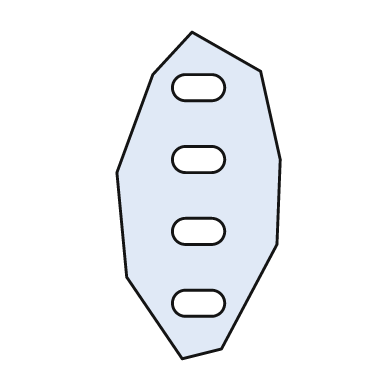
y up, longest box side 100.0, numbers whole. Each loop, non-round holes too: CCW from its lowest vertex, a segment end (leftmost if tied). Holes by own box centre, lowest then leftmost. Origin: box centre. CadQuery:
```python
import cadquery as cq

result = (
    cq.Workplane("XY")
    .moveTo(-5.0, -50.0)
    .lineTo(7.0, -47.0)
    .lineTo(24.0, -15.0)
    .lineTo(25.0, 11.0)
    .lineTo(19.0, 38.0)
    .lineTo(-2.0, 50.0)
    .lineTo(-14.0, 37.0)
    .lineTo(-25.0, 7.0)
    .lineTo(-22.0, -25.0)
    .close()
    .moveTo(-4.0, -37.0)
    .lineTo(4.0, -37.0)
    .threePointArc((8.0, -33.0), (4.0, -29.0))
    .lineTo(-4.0, -29.0)
    .threePointArc((-8.0, -33.0), (-4.0, -37.0))
    .close()
    .moveTo(-4.0, -15.0)
    .lineTo(4.0, -15.0)
    .threePointArc((8.0, -11.0), (4.0, -7.0))
    .lineTo(-4.0, -7.0)
    .threePointArc((-8.0, -11.0), (-4.0, -15.0))
    .close()
    .moveTo(-4.0, 7.0)
    .lineTo(4.0, 7.0)
    .threePointArc((8.0, 11.0), (4.0, 15.0))
    .lineTo(-4.0, 15.0)
    .threePointArc((-8.0, 11.0), (-4.0, 7.0))
    .close()
    .moveTo(-4.0, 29.0)
    .lineTo(4.0, 29.0)
    .threePointArc((8.0, 33.0), (4.0, 37.0))
    .lineTo(-4.0, 37.0)
    .threePointArc((-8.0, 33.0), (-4.0, 29.0))
    .close()
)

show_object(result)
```